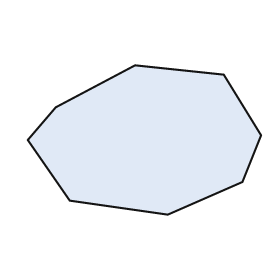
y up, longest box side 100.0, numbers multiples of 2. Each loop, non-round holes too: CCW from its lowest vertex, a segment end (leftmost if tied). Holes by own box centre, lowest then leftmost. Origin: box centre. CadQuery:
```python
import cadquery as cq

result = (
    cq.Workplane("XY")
    .moveTo(10.0, -32.0)
    .lineTo(42.0, -18.0)
    .lineTo(50.0, 2.0)
    .lineTo(34.0, 28.0)
    .lineTo(-4.0, 32.0)
    .lineTo(-38.0, 14.0)
    .lineTo(-50.0, 0.0)
    .lineTo(-32.0, -26.0)
    .close()
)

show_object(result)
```